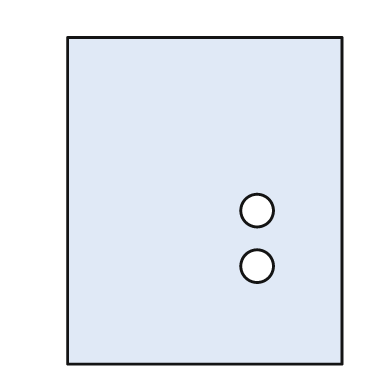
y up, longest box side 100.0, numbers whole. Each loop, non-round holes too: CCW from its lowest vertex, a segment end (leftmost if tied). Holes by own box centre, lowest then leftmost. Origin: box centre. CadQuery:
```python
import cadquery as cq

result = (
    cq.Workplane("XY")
    .moveTo(-42.0, -50.0)
    .lineTo(42.0, -50.0)
    .lineTo(42.0, 50.0)
    .lineTo(-42.0, 50.0)
    .close()
    .moveTo(16.0, -20.0)
    .circle(5.0)
    .moveTo(16.0, -3.0)
    .circle(5.0)
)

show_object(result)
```